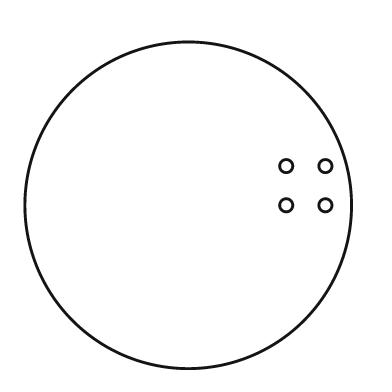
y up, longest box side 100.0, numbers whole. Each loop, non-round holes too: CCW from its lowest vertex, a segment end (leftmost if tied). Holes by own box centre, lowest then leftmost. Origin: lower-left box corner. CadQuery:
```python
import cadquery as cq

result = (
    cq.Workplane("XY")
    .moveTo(50.0, 50.0)
    .circle(50.0)
    .moveTo(80.0, 50.0)
    .circle(2.0)
    .moveTo(92.0, 50.0)
    .circle(2.0)
    .moveTo(80.0, 62.0)
    .circle(2.0)
    .moveTo(92.0, 62.0)
    .circle(2.0)
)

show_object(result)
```